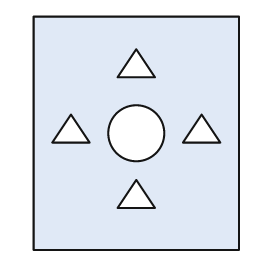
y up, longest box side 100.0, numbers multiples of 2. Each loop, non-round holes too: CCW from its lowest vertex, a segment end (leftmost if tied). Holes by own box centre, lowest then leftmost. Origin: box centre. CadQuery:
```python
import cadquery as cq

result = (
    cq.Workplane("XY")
    .moveTo(-44.0, -50.0)
    .lineTo(44.0, -50.0)
    .lineTo(44.0, 50.0)
    .lineTo(-44.0, 50.0)
    .close()
    .moveTo(-8.0, -32.0)
    .lineTo(8.0, -32.0)
    .lineTo(0.0, -20.0)
    .close()
    .moveTo(0.0, 0.0)
    .circle(12.0)
    .moveTo(-36.0, -4.0)
    .lineTo(-20.0, -4.0)
    .lineTo(-28.0, 8.0)
    .close()
    .moveTo(20.0, -4.0)
    .lineTo(36.0, -4.0)
    .lineTo(28.0, 8.0)
    .close()
    .moveTo(-8.0, 24.0)
    .lineTo(8.0, 24.0)
    .lineTo(0.0, 36.0)
    .close()
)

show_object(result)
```